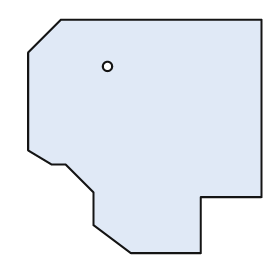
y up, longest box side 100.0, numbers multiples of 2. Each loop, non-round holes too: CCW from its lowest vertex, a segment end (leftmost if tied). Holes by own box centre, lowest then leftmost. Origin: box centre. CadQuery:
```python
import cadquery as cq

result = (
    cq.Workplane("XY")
    .moveTo(-6.0, -50.0)
    .lineTo(24.0, -50.0)
    .lineTo(24.0, -26.0)
    .lineTo(50.0, -26.0)
    .lineTo(50.0, 50.0)
    .lineTo(-36.0, 50.0)
    .lineTo(-50.0, 36.0)
    .lineTo(-50.0, -6.0)
    .lineTo(-40.0, -12.0)
    .lineTo(-34.0, -12.0)
    .lineTo(-22.0, -24.0)
    .lineTo(-22.0, -38.0)
    .close()
    .moveTo(-16.0, 30.0)
    .circle(2.0)
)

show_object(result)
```